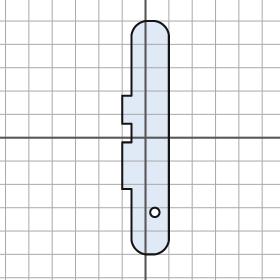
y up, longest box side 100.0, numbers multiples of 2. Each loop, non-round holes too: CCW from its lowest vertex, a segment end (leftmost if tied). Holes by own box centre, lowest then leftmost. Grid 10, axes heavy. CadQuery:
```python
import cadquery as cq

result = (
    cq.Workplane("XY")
    .moveTo(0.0, -50.0)
    .lineTo(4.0, -50.0)
    .threePointArc((8.0, -48.0), (10.0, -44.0))
    .lineTo(10.0, 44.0)
    .threePointArc((8.0, 48.0), (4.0, 50.0))
    .lineTo(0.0, 50.0)
    .threePointArc((-4.0, 48.0), (-6.0, 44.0))
    .lineTo(-6.0, 18.0)
    .lineTo(-10.0, 18.0)
    .lineTo(-10.0, 6.0)
    .lineTo(-6.0, 6.0)
    .lineTo(-6.0, -2.0)
    .lineTo(-10.0, -2.0)
    .lineTo(-10.0, -22.0)
    .lineTo(-6.0, -22.0)
    .lineTo(-6.0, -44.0)
    .threePointArc((-4.0, -48.0), (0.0, -50.0))
    .close()
    .moveTo(4.0, -32.0)
    .circle(2.0)
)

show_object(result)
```